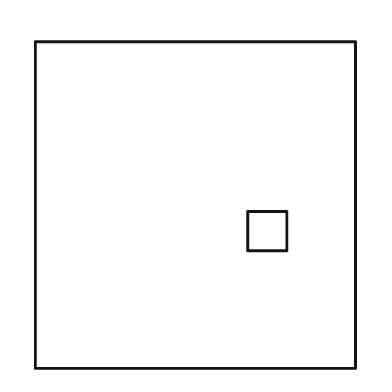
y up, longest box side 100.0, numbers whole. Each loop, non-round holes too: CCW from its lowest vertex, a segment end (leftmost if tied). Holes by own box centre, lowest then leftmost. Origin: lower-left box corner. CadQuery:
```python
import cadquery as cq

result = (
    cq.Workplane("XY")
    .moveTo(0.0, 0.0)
    .lineTo(98.0, 0.0)
    .lineTo(98.0, 100.0)
    .lineTo(0.0, 100.0)
    .close()
    .moveTo(65.0, 36.0)
    .lineTo(77.0, 36.0)
    .lineTo(77.0, 48.0)
    .lineTo(65.0, 48.0)
    .close()
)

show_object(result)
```